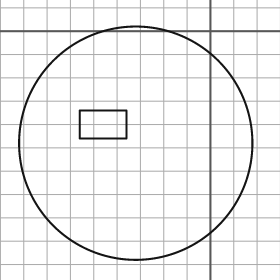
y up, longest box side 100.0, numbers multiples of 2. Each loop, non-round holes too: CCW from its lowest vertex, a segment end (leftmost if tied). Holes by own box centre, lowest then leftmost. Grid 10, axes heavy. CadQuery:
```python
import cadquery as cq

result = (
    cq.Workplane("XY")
    .moveTo(-32.0, -48.0)
    .circle(50.0)
    .moveTo(-56.0, -46.0)
    .lineTo(-36.0, -46.0)
    .lineTo(-36.0, -34.0)
    .lineTo(-56.0, -34.0)
    .close()
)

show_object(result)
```